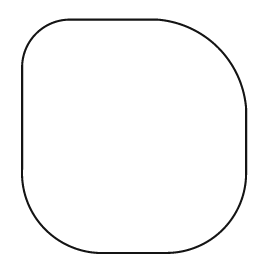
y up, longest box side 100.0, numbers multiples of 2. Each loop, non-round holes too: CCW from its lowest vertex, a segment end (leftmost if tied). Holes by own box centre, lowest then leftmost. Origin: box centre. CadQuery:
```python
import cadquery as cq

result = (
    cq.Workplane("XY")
    .moveTo(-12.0, -50.0)
    .lineTo(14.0, -50.0)
    .threePointArc((38.0, -40.0), (48.0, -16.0))
    .lineTo(48.0, 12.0)
    .threePointArc((36.0, 38.0), (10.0, 50.0))
    .lineTo(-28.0, 50.0)
    .threePointArc((-42.0, 44.0), (-48.0, 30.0))
    .lineTo(-48.0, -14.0)
    .threePointArc((-38.0, -40.0), (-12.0, -50.0))
    .close()
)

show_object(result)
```